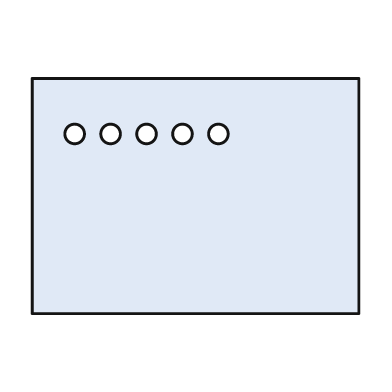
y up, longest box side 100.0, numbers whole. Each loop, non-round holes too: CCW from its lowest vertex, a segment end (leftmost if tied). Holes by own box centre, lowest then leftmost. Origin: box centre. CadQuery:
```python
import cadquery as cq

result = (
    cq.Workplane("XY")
    .moveTo(-50.0, -36.0)
    .lineTo(50.0, -36.0)
    .lineTo(50.0, 36.0)
    .lineTo(-50.0, 36.0)
    .close()
    .moveTo(-37.0, 19.0)
    .circle(3.0)
    .moveTo(-26.0, 19.0)
    .circle(3.0)
    .moveTo(-15.0, 19.0)
    .circle(3.0)
    .moveTo(-4.0, 19.0)
    .circle(3.0)
    .moveTo(7.0, 19.0)
    .circle(3.0)
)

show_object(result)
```